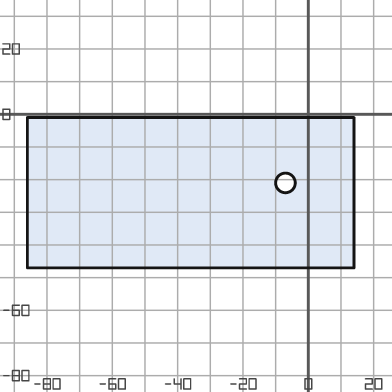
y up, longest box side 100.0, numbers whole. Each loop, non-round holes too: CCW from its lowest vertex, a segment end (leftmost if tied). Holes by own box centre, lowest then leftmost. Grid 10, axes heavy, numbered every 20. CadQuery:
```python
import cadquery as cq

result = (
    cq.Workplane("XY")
    .moveTo(-86.0, -47.0)
    .lineTo(14.0, -47.0)
    .lineTo(14.0, -1.0)
    .lineTo(-86.0, -1.0)
    .close()
    .moveTo(-7.0, -21.0)
    .circle(3.0)
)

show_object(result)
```